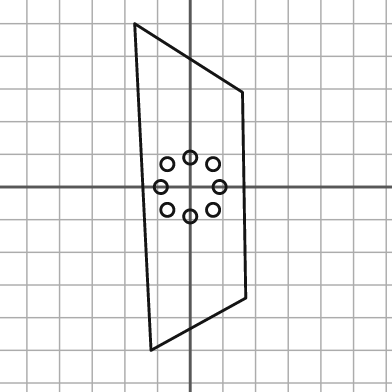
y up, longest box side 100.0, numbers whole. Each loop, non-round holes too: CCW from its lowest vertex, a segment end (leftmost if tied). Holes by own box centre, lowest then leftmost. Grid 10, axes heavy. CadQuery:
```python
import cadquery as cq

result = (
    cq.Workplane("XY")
    .moveTo(-12.0, -50.0)
    .lineTo(17.0, -34.0)
    .lineTo(16.0, 29.0)
    .lineTo(-17.0, 50.0)
    .close()
    .moveTo(0.0, -9.0)
    .circle(2.0)
    .moveTo(-7.0, -7.0)
    .circle(2.0)
    .moveTo(7.0, -7.0)
    .circle(2.0)
    .moveTo(-9.0, 0.0)
    .circle(2.0)
    .moveTo(9.0, 0.0)
    .circle(2.0)
    .moveTo(-7.0, 7.0)
    .circle(2.0)
    .moveTo(7.0, 7.0)
    .circle(2.0)
    .moveTo(0.0, 9.0)
    .circle(2.0)
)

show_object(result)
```